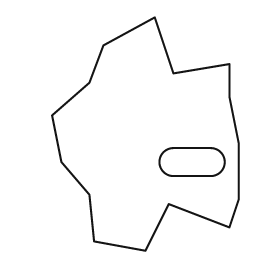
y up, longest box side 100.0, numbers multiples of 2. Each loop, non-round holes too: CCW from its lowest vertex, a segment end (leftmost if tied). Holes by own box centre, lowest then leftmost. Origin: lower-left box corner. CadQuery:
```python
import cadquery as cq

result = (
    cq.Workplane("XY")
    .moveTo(40.0, 0.0)
    .lineTo(50.0, 20.0)
    .lineTo(76.0, 10.0)
    .lineTo(80.0, 22.0)
    .lineTo(80.0, 46.0)
    .lineTo(76.0, 66.0)
    .lineTo(76.0, 80.0)
    .lineTo(52.0, 76.0)
    .lineTo(44.0, 100.0)
    .lineTo(22.0, 88.0)
    .lineTo(16.0, 72.0)
    .lineTo(0.0, 58.0)
    .lineTo(4.0, 38.0)
    .lineTo(16.0, 24.0)
    .lineTo(18.0, 4.0)
    .close()
    .moveTo(52.0, 32.0)
    .lineTo(68.0, 32.0)
    .threePointArc((74.0, 38.0), (68.0, 44.0))
    .lineTo(52.0, 44.0)
    .threePointArc((46.0, 38.0), (52.0, 32.0))
    .close()
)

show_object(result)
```